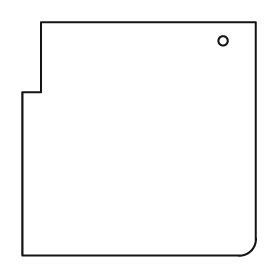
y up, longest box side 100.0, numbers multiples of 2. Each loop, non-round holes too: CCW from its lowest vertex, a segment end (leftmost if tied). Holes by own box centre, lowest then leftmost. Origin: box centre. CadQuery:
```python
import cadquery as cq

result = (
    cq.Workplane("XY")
    .moveTo(-50.0, -50.0)
    .lineTo(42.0, -50.0)
    .threePointArc((48.0, -48.0), (50.0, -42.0))
    .lineTo(50.0, 50.0)
    .lineTo(-42.0, 50.0)
    .lineTo(-42.0, 20.0)
    .lineTo(-50.0, 20.0)
    .close()
    .moveTo(36.0, 42.0)
    .circle(2.0)
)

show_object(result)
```